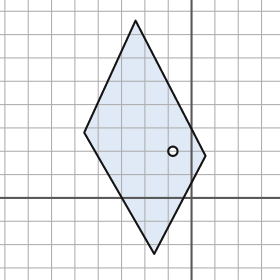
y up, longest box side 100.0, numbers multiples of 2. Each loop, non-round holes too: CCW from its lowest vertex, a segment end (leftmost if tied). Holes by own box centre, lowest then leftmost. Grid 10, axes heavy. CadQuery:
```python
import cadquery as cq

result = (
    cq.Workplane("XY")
    .moveTo(-16.0, -24.0)
    .lineTo(6.0, 18.0)
    .lineTo(-24.0, 76.0)
    .lineTo(-46.0, 28.0)
    .close()
    .moveTo(-8.0, 20.0)
    .circle(2.0)
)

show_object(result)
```